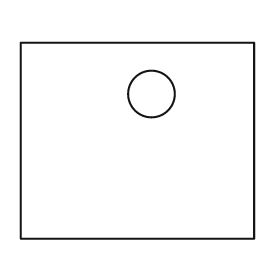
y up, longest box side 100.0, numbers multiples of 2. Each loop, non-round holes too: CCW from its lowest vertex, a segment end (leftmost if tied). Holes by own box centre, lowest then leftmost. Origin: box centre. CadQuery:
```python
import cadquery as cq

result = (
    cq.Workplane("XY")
    .moveTo(-50.0, -42.0)
    .lineTo(50.0, -42.0)
    .lineTo(50.0, 42.0)
    .lineTo(-50.0, 42.0)
    .close()
    .moveTo(6.0, 20.0)
    .circle(10.0)
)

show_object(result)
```